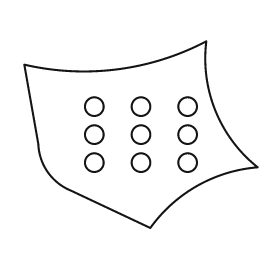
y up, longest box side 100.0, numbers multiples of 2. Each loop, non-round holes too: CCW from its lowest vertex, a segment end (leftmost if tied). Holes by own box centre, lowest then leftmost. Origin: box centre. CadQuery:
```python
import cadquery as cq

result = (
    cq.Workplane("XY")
    .moveTo(4.0, -40.0)
    .threePointArc((24.0, -22.0), (50.0, -14.0))
    .threePointArc((32.0, 10.0), (28.0, 40.0))
    .threePointArc((-10.0, 28.0), (-50.0, 30.0))
    .lineTo(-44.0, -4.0)
    .threePointArc((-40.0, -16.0), (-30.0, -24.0))
    .close()
    .moveTo(-20.0, -12.0)
    .circle(4.0)
    .moveTo(0.0, -12.0)
    .circle(4.0)
    .moveTo(20.0, -12.0)
    .circle(4.0)
    .moveTo(-20.0, 0.0)
    .circle(4.0)
    .moveTo(0.0, 0.0)
    .circle(4.0)
    .moveTo(20.0, 0.0)
    .circle(4.0)
    .moveTo(-20.0, 12.0)
    .circle(4.0)
    .moveTo(0.0, 12.0)
    .circle(4.0)
    .moveTo(20.0, 12.0)
    .circle(4.0)
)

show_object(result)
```